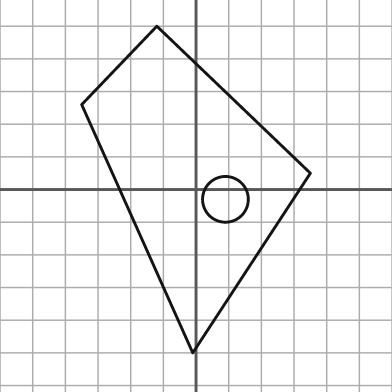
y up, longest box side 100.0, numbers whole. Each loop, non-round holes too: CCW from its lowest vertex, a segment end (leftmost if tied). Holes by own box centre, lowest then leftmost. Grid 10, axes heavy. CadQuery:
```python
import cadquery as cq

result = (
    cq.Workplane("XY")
    .moveTo(-1.0, -50.0)
    .lineTo(35.0, 5.0)
    .lineTo(-12.0, 50.0)
    .lineTo(-35.0, 26.0)
    .close()
    .moveTo(9.0, -3.0)
    .circle(7.0)
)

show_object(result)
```